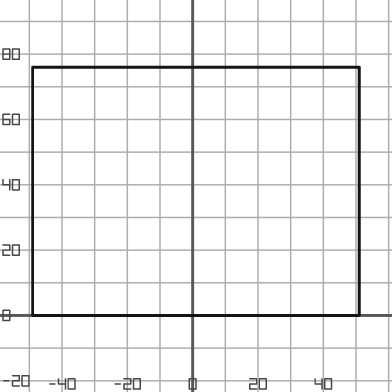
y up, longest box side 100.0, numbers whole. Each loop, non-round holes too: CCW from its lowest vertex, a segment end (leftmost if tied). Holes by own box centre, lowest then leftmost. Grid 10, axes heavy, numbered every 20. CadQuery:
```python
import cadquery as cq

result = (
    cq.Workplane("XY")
    .moveTo(-49.0, 0.0)
    .lineTo(51.0, 0.0)
    .lineTo(51.0, 76.0)
    .lineTo(-49.0, 76.0)
    .close()
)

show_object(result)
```